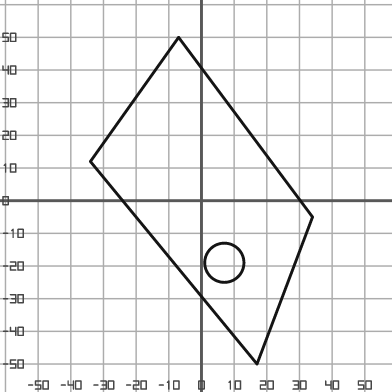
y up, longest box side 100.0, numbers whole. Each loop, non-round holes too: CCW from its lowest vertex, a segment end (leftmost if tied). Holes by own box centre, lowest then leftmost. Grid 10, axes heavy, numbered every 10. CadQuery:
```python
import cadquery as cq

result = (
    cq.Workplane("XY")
    .moveTo(17.0, -50.0)
    .lineTo(34.0, -5.0)
    .lineTo(-7.0, 50.0)
    .lineTo(-34.0, 12.0)
    .close()
    .moveTo(7.0, -19.0)
    .circle(6.0)
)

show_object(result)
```